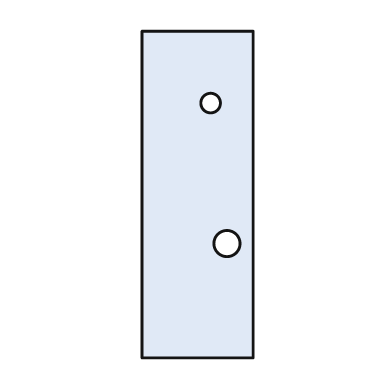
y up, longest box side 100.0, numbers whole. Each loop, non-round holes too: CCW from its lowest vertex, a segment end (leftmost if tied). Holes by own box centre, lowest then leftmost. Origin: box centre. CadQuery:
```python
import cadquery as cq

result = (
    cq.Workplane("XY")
    .moveTo(-17.0, -50.0)
    .lineTo(17.0, -50.0)
    .lineTo(17.0, 50.0)
    .lineTo(-17.0, 50.0)
    .close()
    .moveTo(9.0, -15.0)
    .circle(4.0)
    .moveTo(4.0, 28.0)
    .circle(3.0)
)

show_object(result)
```